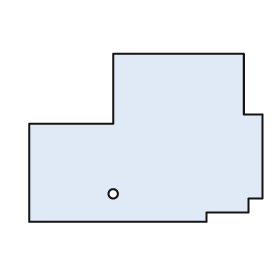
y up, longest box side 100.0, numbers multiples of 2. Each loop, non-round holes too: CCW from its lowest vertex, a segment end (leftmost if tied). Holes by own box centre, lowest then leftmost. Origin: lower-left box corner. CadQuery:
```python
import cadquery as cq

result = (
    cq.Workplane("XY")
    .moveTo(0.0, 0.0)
    .lineTo(76.0, 0.0)
    .lineTo(76.0, 4.0)
    .lineTo(94.0, 4.0)
    .lineTo(94.0, 10.0)
    .lineTo(100.0, 10.0)
    .lineTo(100.0, 46.0)
    .lineTo(92.0, 46.0)
    .lineTo(92.0, 72.0)
    .lineTo(36.0, 72.0)
    .lineTo(36.0, 42.0)
    .lineTo(0.0, 42.0)
    .close()
    .moveTo(36.0, 12.0)
    .circle(2.0)
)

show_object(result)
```